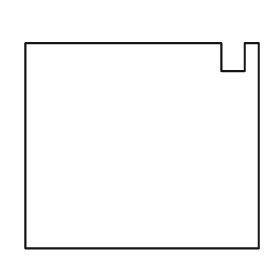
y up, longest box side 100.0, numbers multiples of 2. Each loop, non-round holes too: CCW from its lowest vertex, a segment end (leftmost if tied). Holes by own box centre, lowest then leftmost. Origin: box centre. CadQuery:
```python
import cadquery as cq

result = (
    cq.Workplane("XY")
    .moveTo(-50.0, -44.0)
    .lineTo(50.0, -44.0)
    .lineTo(50.0, 44.0)
    .lineTo(44.0, 44.0)
    .lineTo(44.0, 32.0)
    .lineTo(34.0, 32.0)
    .lineTo(34.0, 44.0)
    .lineTo(-50.0, 44.0)
    .close()
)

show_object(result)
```